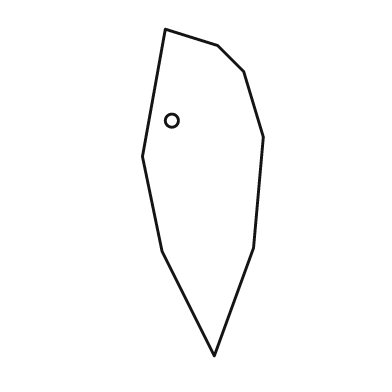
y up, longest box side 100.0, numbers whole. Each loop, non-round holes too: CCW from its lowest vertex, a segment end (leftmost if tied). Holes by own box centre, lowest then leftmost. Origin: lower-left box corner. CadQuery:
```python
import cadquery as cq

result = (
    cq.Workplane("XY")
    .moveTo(22.0, 0.0)
    .lineTo(34.0, 33.0)
    .lineTo(37.0, 67.0)
    .lineTo(31.0, 87.0)
    .lineTo(23.0, 95.0)
    .lineTo(7.0, 100.0)
    .lineTo(0.0, 61.0)
    .lineTo(6.0, 32.0)
    .close()
    .moveTo(9.0, 72.0)
    .circle(2.0)
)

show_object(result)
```